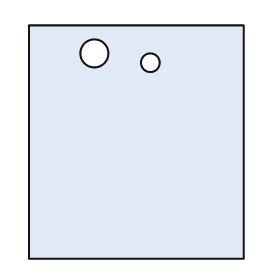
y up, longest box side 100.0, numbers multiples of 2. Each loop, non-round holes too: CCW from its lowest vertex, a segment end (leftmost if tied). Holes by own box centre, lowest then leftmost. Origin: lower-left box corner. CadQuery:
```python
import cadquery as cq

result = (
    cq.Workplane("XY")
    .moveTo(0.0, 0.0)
    .lineTo(92.0, 0.0)
    .lineTo(92.0, 100.0)
    .lineTo(0.0, 100.0)
    .close()
    .moveTo(52.0, 84.0)
    .circle(4.0)
    .moveTo(28.0, 88.0)
    .circle(6.0)
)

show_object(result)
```